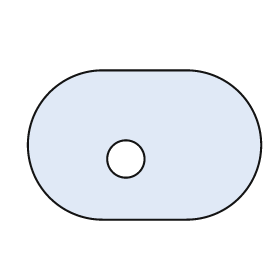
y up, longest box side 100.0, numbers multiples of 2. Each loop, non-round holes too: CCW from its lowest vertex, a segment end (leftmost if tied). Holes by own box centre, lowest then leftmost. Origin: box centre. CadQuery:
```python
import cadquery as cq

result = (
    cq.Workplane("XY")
    .moveTo(-18.0, -32.0)
    .lineTo(18.0, -32.0)
    .threePointArc((50.0, 0.0), (18.0, 32.0))
    .lineTo(-18.0, 32.0)
    .threePointArc((-50.0, 0.0), (-18.0, -32.0))
    .close()
    .moveTo(-8.0, -6.0)
    .circle(8.0)
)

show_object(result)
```